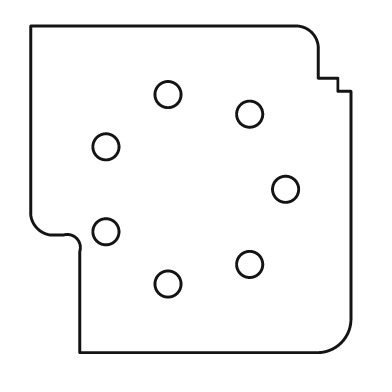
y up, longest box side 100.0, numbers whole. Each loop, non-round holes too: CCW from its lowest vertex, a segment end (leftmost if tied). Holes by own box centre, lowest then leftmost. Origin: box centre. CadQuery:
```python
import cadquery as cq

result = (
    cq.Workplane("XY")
    .moveTo(-34.0, -50.0)
    .lineTo(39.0, -50.0)
    .threePointArc((46.0, -47.0), (49.0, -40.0))
    .lineTo(49.0, 30.0)
    .lineTo(45.0, 30.0)
    .lineTo(45.0, 34.0)
    .lineTo(39.0, 34.0)
    .lineTo(39.0, 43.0)
    .threePointArc((37.0, 48.0), (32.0, 50.0))
    .lineTo(-49.0, 50.0)
    .lineTo(-49.0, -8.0)
    .threePointArc((-47.0, -12.0), (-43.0, -14.0))
    .lineTo(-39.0, -14.0)
    .threePointArc((-35.0, -15.0), (-34.0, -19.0))
    .close()
    .moveTo(-7.0, -29.0)
    .circle(4.0)
    .moveTo(18.0, -23.0)
    .circle(4.0)
    .moveTo(-26.0, -13.0)
    .circle(4.0)
    .moveTo(29.0, 0.0)
    .circle(4.0)
    .moveTo(-26.0, 13.0)
    .circle(4.0)
    .moveTo(18.0, 23.0)
    .circle(4.0)
    .moveTo(-7.0, 29.0)
    .circle(4.0)
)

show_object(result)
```